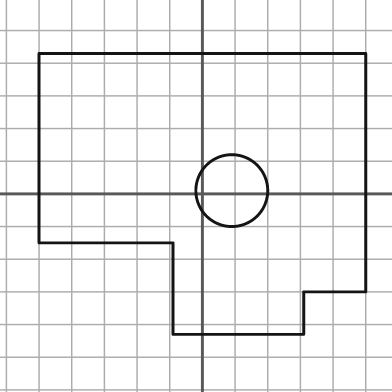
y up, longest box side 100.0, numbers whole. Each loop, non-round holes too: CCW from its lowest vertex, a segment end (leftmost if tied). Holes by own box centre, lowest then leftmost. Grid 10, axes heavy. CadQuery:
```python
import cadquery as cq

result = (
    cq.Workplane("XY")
    .moveTo(-9.0, -43.0)
    .lineTo(31.0, -43.0)
    .lineTo(31.0, -30.0)
    .lineTo(50.0, -30.0)
    .lineTo(50.0, 43.0)
    .lineTo(-50.0, 43.0)
    .lineTo(-50.0, -15.0)
    .lineTo(-9.0, -15.0)
    .close()
    .moveTo(9.0, 1.0)
    .circle(11.0)
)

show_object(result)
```